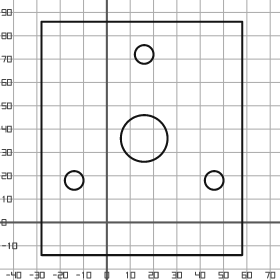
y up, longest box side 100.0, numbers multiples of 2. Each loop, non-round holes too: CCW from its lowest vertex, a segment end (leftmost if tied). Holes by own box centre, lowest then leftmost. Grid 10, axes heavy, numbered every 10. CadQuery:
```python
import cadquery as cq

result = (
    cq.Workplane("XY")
    .moveTo(-28.0, -14.0)
    .lineTo(58.0, -14.0)
    .lineTo(58.0, 86.0)
    .lineTo(-28.0, 86.0)
    .close()
    .moveTo(-14.0, 18.0)
    .circle(4.0)
    .moveTo(46.0, 18.0)
    .circle(4.0)
    .moveTo(16.0, 36.0)
    .circle(10.0)
    .moveTo(16.0, 72.0)
    .circle(4.0)
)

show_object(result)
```